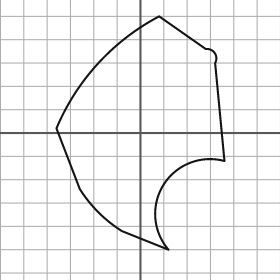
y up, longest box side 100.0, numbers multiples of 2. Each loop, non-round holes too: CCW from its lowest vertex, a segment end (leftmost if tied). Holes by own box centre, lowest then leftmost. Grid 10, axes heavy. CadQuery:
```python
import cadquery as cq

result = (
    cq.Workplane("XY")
    .moveTo(12.0, -50.0)
    .threePointArc((10.0, -22.0), (36.0, -12.0))
    .lineTo(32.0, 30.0)
    .threePointArc((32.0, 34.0), (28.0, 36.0))
    .lineTo(8.0, 50.0)
    .threePointArc((-18.0, 30.0), (-36.0, 2.0))
    .lineTo(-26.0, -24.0)
    .threePointArc((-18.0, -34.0), (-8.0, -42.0))
    .close()
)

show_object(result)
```